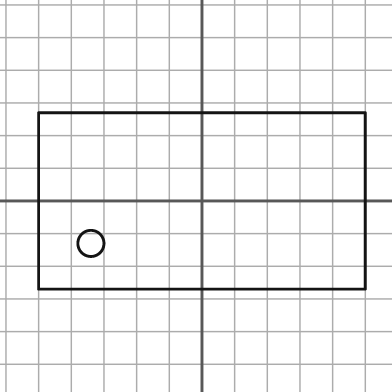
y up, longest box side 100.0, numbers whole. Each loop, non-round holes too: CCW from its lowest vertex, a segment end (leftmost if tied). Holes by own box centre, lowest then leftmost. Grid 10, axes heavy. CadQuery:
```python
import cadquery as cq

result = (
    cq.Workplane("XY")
    .moveTo(-50.0, -27.0)
    .lineTo(50.0, -27.0)
    .lineTo(50.0, 27.0)
    .lineTo(-50.0, 27.0)
    .close()
    .moveTo(-34.0, -13.0)
    .circle(4.0)
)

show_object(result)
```